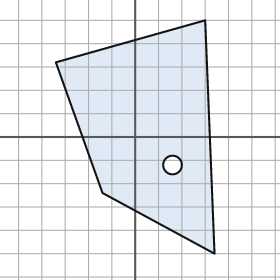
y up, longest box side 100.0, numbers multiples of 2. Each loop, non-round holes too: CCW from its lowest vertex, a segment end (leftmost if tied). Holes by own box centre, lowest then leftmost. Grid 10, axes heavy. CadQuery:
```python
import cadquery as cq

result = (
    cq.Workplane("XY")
    .moveTo(34.0, -50.0)
    .lineTo(30.0, 50.0)
    .lineTo(-34.0, 32.0)
    .lineTo(-14.0, -24.0)
    .close()
    .moveTo(16.0, -12.0)
    .circle(4.0)
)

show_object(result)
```